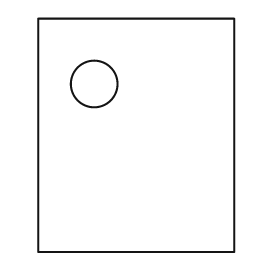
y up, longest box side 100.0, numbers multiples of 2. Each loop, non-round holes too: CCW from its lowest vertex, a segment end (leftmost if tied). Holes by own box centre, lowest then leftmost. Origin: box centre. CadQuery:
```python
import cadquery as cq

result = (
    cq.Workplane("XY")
    .moveTo(-42.0, -50.0)
    .lineTo(42.0, -50.0)
    .lineTo(42.0, 50.0)
    .lineTo(-42.0, 50.0)
    .close()
    .moveTo(-18.0, 22.0)
    .circle(10.0)
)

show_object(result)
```